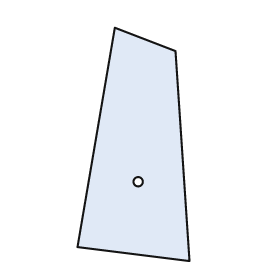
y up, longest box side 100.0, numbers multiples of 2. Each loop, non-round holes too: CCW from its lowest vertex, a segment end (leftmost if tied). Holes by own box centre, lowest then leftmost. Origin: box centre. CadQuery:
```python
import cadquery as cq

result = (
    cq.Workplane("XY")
    .moveTo(24.0, -50.0)
    .lineTo(18.0, 40.0)
    .lineTo(-8.0, 50.0)
    .lineTo(-24.0, -44.0)
    .close()
    .moveTo(2.0, -16.0)
    .circle(2.0)
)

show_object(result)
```